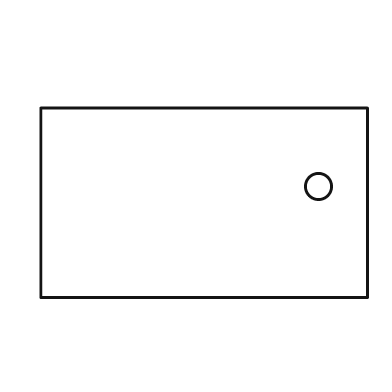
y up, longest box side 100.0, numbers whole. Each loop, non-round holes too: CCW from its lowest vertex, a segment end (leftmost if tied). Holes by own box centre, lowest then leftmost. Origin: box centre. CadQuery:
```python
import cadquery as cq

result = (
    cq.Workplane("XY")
    .moveTo(-50.0, -29.0)
    .lineTo(50.0, -29.0)
    .lineTo(50.0, 29.0)
    .lineTo(-50.0, 29.0)
    .close()
    .moveTo(35.0, 5.0)
    .circle(4.0)
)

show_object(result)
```